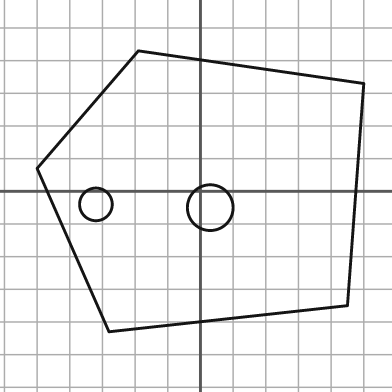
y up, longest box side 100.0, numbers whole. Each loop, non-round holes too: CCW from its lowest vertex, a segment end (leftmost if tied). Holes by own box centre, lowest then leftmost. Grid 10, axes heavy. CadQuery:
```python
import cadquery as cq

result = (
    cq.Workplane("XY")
    .moveTo(-28.0, -43.0)
    .lineTo(45.0, -35.0)
    .lineTo(50.0, 33.0)
    .lineTo(-19.0, 43.0)
    .lineTo(-50.0, 7.0)
    .close()
    .moveTo(3.0, -5.0)
    .circle(7.0)
    .moveTo(-32.0, -4.0)
    .circle(5.0)
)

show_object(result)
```